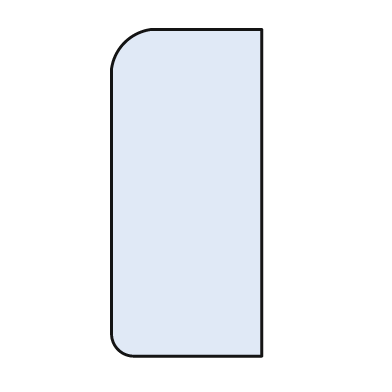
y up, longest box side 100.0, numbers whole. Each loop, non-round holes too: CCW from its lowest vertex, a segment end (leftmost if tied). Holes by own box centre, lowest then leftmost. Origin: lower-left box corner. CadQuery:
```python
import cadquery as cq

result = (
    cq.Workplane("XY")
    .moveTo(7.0, 0.0)
    .lineTo(46.0, 0.0)
    .lineTo(46.0, 100.0)
    .lineTo(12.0, 100.0)
    .threePointArc((4.0, 96.0), (0.0, 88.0))
    .lineTo(0.0, 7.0)
    .threePointArc((2.0, 2.0), (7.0, 0.0))
    .close()
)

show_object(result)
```